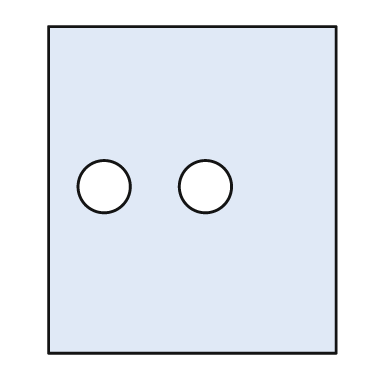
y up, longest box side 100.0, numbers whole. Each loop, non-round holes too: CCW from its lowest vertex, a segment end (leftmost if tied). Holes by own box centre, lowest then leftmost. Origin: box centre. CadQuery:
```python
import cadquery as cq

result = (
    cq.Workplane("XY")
    .moveTo(-44.0, -50.0)
    .lineTo(44.0, -50.0)
    .lineTo(44.0, 50.0)
    .lineTo(-44.0, 50.0)
    .close()
    .moveTo(-27.0, 1.0)
    .circle(8.0)
    .moveTo(4.0, 1.0)
    .circle(8.0)
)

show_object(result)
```